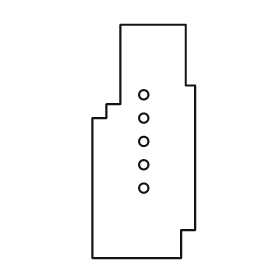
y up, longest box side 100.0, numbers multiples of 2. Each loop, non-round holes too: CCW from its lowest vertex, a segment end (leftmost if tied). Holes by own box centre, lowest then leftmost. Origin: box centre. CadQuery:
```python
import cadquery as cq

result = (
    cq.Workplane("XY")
    .moveTo(-22.0, -50.0)
    .lineTo(16.0, -50.0)
    .lineTo(16.0, -38.0)
    .lineTo(22.0, -38.0)
    .lineTo(22.0, 24.0)
    .lineTo(18.0, 24.0)
    .lineTo(18.0, 50.0)
    .lineTo(-10.0, 50.0)
    .lineTo(-10.0, 16.0)
    .lineTo(-16.0, 16.0)
    .lineTo(-16.0, 10.0)
    .lineTo(-22.0, 10.0)
    .close()
    .moveTo(0.0, -20.0)
    .circle(2.0)
    .moveTo(0.0, -10.0)
    .circle(2.0)
    .moveTo(0.0, 0.0)
    .circle(2.0)
    .moveTo(0.0, 10.0)
    .circle(2.0)
    .moveTo(0.0, 20.0)
    .circle(2.0)
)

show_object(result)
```